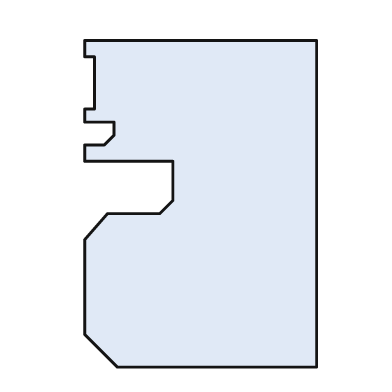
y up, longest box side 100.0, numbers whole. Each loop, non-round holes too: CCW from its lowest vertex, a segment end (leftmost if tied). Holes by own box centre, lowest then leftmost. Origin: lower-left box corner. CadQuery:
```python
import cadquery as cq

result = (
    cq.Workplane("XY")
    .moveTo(10.0, 0.0)
    .lineTo(71.0, 0.0)
    .lineTo(71.0, 100.0)
    .lineTo(0.0, 100.0)
    .lineTo(0.0, 95.0)
    .lineTo(3.0, 95.0)
    .lineTo(3.0, 79.0)
    .lineTo(0.0, 79.0)
    .lineTo(0.0, 75.0)
    .lineTo(9.0, 75.0)
    .lineTo(9.0, 71.0)
    .lineTo(6.0, 68.0)
    .lineTo(0.0, 68.0)
    .lineTo(0.0, 63.0)
    .lineTo(27.0, 63.0)
    .lineTo(27.0, 51.0)
    .lineTo(23.0, 47.0)
    .lineTo(7.0, 47.0)
    .lineTo(0.0, 39.0)
    .lineTo(0.0, 10.0)
    .close()
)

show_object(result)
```